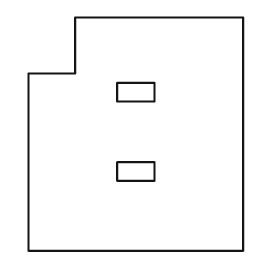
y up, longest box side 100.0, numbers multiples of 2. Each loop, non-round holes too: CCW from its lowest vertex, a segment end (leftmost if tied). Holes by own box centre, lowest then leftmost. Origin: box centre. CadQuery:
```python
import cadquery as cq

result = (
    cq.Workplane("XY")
    .moveTo(-46.0, -50.0)
    .lineTo(46.0, -50.0)
    .lineTo(46.0, 50.0)
    .lineTo(-26.0, 50.0)
    .lineTo(-26.0, 26.0)
    .lineTo(-46.0, 26.0)
    .close()
    .moveTo(-8.0, -20.0)
    .lineTo(8.0, -20.0)
    .lineTo(8.0, -12.0)
    .lineTo(-8.0, -12.0)
    .close()
    .moveTo(-8.0, 14.0)
    .lineTo(8.0, 14.0)
    .lineTo(8.0, 22.0)
    .lineTo(-8.0, 22.0)
    .close()
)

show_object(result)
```